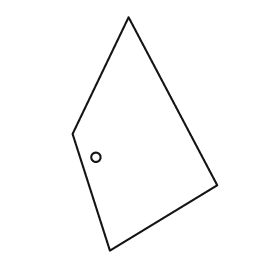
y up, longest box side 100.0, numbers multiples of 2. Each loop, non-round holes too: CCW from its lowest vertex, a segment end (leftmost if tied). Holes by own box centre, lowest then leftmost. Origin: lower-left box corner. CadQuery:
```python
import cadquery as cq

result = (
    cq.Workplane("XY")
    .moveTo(16.0, 0.0)
    .lineTo(62.0, 28.0)
    .lineTo(24.0, 100.0)
    .lineTo(0.0, 50.0)
    .close()
    .moveTo(10.0, 40.0)
    .circle(2.0)
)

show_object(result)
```